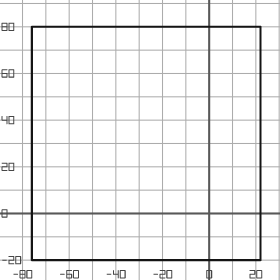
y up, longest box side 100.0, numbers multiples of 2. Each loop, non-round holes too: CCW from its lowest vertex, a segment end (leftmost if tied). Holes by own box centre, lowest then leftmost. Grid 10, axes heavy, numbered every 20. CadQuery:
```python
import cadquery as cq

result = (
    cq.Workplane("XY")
    .moveTo(-76.0, -20.0)
    .lineTo(22.0, -20.0)
    .lineTo(22.0, 80.0)
    .lineTo(-76.0, 80.0)
    .close()
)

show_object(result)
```